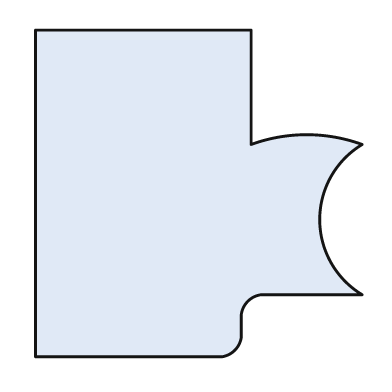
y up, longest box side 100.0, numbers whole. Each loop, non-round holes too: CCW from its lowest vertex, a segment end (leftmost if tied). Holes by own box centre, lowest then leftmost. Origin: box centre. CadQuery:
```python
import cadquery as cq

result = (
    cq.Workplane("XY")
    .moveTo(-50.0, -50.0)
    .lineTo(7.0, -50.0)
    .threePointArc((11.0, -48.0), (13.0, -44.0))
    .lineTo(13.0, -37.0)
    .threePointArc((15.0, -33.0), (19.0, -31.0))
    .lineTo(50.0, -31.0)
    .threePointArc((37.0, -8.0), (50.0, 15.0))
    .threePointArc((33.0, 18.0), (16.0, 15.0))
    .lineTo(16.0, 50.0)
    .lineTo(-50.0, 50.0)
    .close()
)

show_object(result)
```